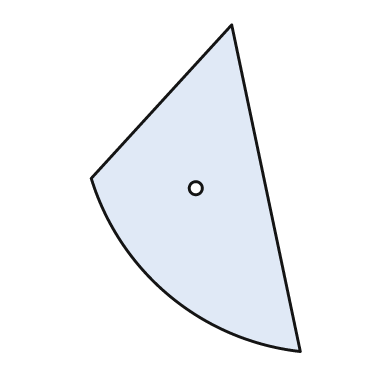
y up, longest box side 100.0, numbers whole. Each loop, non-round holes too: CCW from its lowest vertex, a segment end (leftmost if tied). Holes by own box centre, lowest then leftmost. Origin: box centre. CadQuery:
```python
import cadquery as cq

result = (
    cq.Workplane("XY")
    .moveTo(32.0, -50.0)
    .lineTo(11.0, 50.0)
    .lineTo(-32.0, 3.0)
    .threePointArc((-8.0, -33.0), (32.0, -50.0))
    .close()
    .moveTo(0.0, 0.0)
    .circle(2.0)
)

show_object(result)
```